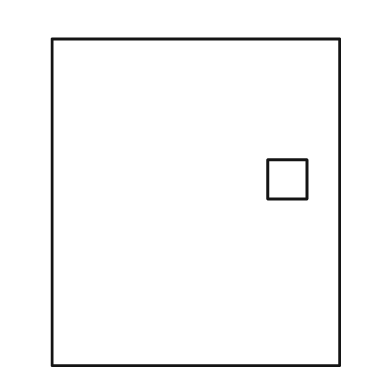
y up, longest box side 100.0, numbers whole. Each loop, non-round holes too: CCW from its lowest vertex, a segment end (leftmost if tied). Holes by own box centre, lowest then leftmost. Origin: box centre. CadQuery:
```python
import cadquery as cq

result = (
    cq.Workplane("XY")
    .moveTo(-44.0, -50.0)
    .lineTo(44.0, -50.0)
    .lineTo(44.0, 50.0)
    .lineTo(-44.0, 50.0)
    .close()
    .moveTo(22.0, 1.0)
    .lineTo(34.0, 1.0)
    .lineTo(34.0, 13.0)
    .lineTo(22.0, 13.0)
    .close()
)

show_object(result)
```